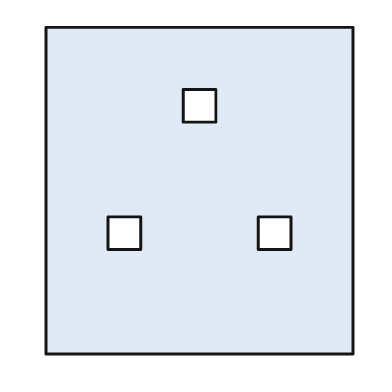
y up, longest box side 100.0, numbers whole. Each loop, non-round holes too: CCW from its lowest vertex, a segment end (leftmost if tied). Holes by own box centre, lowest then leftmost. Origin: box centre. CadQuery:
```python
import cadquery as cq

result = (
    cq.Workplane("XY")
    .moveTo(-47.0, -50.0)
    .lineTo(47.0, -50.0)
    .lineTo(47.0, 50.0)
    .lineTo(-47.0, 50.0)
    .close()
    .moveTo(-28.0, -18.0)
    .lineTo(-18.0, -18.0)
    .lineTo(-18.0, -8.0)
    .lineTo(-28.0, -8.0)
    .close()
    .moveTo(18.0, -18.0)
    .lineTo(28.0, -18.0)
    .lineTo(28.0, -8.0)
    .lineTo(18.0, -8.0)
    .close()
    .moveTo(-5.0, 21.0)
    .lineTo(5.0, 21.0)
    .lineTo(5.0, 31.0)
    .lineTo(-5.0, 31.0)
    .close()
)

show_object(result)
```